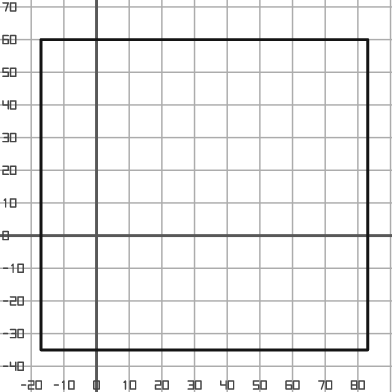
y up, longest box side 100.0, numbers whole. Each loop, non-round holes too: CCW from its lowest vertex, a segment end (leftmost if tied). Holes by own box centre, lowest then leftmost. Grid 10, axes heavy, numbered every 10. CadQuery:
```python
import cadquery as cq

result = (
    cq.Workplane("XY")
    .moveTo(-17.0, -35.0)
    .lineTo(83.0, -35.0)
    .lineTo(83.0, 60.0)
    .lineTo(-17.0, 60.0)
    .close()
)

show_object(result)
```